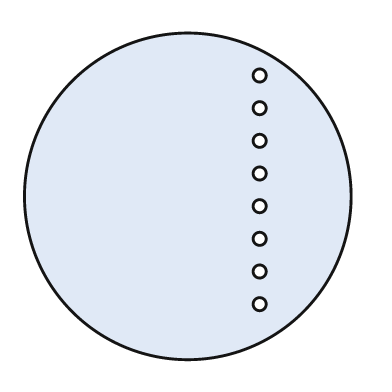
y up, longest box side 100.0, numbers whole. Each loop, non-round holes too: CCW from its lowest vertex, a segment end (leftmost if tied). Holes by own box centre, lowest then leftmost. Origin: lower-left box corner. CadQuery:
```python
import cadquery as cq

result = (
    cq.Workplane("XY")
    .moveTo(50.0, 50.0)
    .circle(50.0)
    .moveTo(72.0, 17.0)
    .circle(2.0)
    .moveTo(72.0, 27.0)
    .circle(2.0)
    .moveTo(72.0, 37.0)
    .circle(2.0)
    .moveTo(72.0, 47.0)
    .circle(2.0)
    .moveTo(72.0, 57.0)
    .circle(2.0)
    .moveTo(72.0, 67.0)
    .circle(2.0)
    .moveTo(72.0, 77.0)
    .circle(2.0)
    .moveTo(72.0, 87.0)
    .circle(2.0)
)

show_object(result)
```